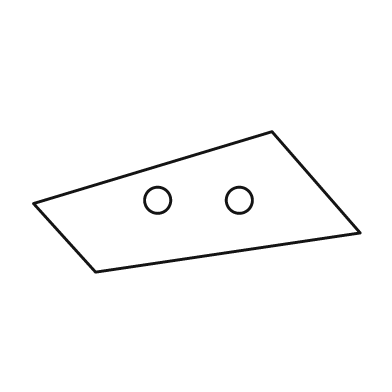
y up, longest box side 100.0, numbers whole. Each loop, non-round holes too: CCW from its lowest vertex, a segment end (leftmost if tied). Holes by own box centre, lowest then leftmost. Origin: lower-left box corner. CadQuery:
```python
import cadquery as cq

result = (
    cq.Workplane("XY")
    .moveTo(19.0, 0.0)
    .lineTo(100.0, 12.0)
    .lineTo(73.0, 43.0)
    .lineTo(0.0, 21.0)
    .close()
    .moveTo(38.0, 22.0)
    .circle(4.0)
    .moveTo(63.0, 22.0)
    .circle(4.0)
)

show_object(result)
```